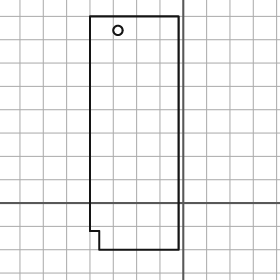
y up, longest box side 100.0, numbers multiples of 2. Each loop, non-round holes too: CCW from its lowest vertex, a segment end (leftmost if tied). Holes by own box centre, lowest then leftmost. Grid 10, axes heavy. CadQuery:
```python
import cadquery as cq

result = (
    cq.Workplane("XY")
    .moveTo(-36.0, -20.0)
    .lineTo(-2.0, -20.0)
    .lineTo(-2.0, 80.0)
    .lineTo(-40.0, 80.0)
    .lineTo(-40.0, -12.0)
    .lineTo(-36.0, -12.0)
    .close()
    .moveTo(-28.0, 74.0)
    .circle(2.0)
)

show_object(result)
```